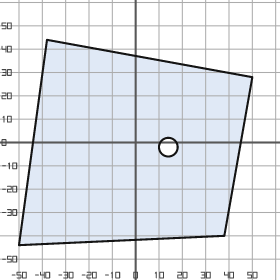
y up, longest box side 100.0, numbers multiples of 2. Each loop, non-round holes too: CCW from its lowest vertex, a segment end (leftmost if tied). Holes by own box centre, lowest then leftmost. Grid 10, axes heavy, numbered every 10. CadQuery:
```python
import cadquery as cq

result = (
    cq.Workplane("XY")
    .moveTo(-50.0, -44.0)
    .lineTo(38.0, -40.0)
    .lineTo(50.0, 28.0)
    .lineTo(-38.0, 44.0)
    .close()
    .moveTo(14.0, -2.0)
    .circle(4.0)
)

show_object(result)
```